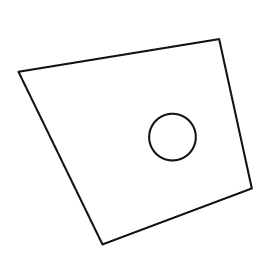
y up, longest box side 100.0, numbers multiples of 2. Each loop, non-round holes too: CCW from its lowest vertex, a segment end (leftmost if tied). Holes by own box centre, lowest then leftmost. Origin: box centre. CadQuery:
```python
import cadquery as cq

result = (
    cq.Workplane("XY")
    .moveTo(-14.0, -44.0)
    .lineTo(50.0, -20.0)
    .lineTo(36.0, 44.0)
    .lineTo(-50.0, 30.0)
    .close()
    .moveTo(16.0, 2.0)
    .circle(10.0)
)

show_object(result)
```